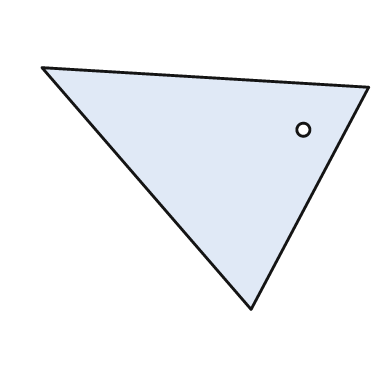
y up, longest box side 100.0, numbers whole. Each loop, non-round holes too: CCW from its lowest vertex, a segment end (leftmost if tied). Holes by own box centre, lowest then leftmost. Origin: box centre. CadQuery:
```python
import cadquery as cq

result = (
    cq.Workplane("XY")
    .moveTo(14.0, -37.0)
    .lineTo(50.0, 31.0)
    .lineTo(-50.0, 37.0)
    .close()
    .moveTo(30.0, 18.0)
    .circle(2.0)
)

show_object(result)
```